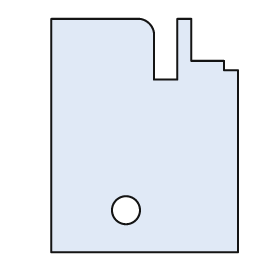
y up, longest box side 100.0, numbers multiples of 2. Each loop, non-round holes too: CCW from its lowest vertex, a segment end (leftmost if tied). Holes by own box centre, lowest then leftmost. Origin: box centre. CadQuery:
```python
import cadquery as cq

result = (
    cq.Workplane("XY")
    .moveTo(-40.0, -50.0)
    .lineTo(40.0, -50.0)
    .lineTo(40.0, 28.0)
    .lineTo(34.0, 28.0)
    .lineTo(34.0, 32.0)
    .lineTo(20.0, 32.0)
    .lineTo(20.0, 50.0)
    .lineTo(14.0, 50.0)
    .lineTo(14.0, 24.0)
    .lineTo(4.0, 24.0)
    .lineTo(4.0, 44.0)
    .threePointArc((2.0, 48.0), (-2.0, 50.0))
    .lineTo(-40.0, 50.0)
    .close()
    .moveTo(-8.0, -32.0)
    .circle(6.0)
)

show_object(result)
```